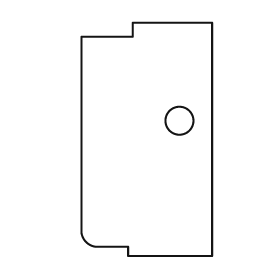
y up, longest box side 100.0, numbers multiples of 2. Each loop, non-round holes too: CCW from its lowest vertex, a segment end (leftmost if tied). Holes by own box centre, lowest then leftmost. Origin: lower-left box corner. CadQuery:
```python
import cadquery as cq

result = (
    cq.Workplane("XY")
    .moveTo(20.0, 0.0)
    .lineTo(56.0, 0.0)
    .lineTo(56.0, 100.0)
    .lineTo(22.0, 100.0)
    .lineTo(22.0, 94.0)
    .lineTo(0.0, 94.0)
    .lineTo(0.0, 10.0)
    .threePointArc((2.0, 6.0), (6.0, 4.0))
    .lineTo(20.0, 4.0)
    .close()
    .moveTo(42.0, 58.0)
    .circle(6.0)
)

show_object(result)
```